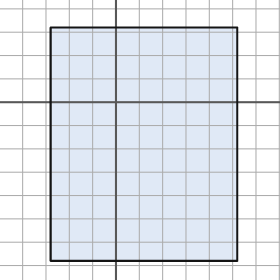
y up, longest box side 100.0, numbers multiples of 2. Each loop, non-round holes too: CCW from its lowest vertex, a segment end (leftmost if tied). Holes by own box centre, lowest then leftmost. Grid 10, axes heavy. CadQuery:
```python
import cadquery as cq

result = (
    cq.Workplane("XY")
    .moveTo(-28.0, -68.0)
    .lineTo(52.0, -68.0)
    .lineTo(52.0, 32.0)
    .lineTo(-28.0, 32.0)
    .close()
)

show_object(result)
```